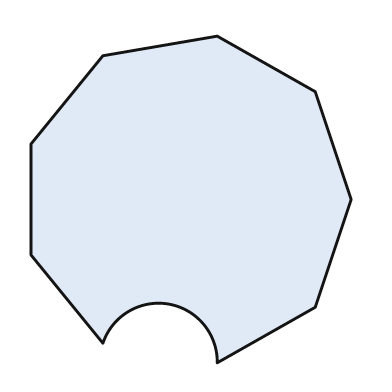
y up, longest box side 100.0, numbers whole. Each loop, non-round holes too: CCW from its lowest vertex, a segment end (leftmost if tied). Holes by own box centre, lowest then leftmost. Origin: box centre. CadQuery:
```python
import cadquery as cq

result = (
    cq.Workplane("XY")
    .moveTo(8.0, -50.0)
    .lineTo(38.0, -33.0)
    .lineTo(49.0, 0.0)
    .lineTo(38.0, 33.0)
    .lineTo(8.0, 50.0)
    .lineTo(-27.0, 44.0)
    .lineTo(-49.0, 17.0)
    .lineTo(-49.0, -17.0)
    .lineTo(-27.0, -44.0)
    .threePointArc((-7.0, -32.0), (8.0, -50.0))
    .close()
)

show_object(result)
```